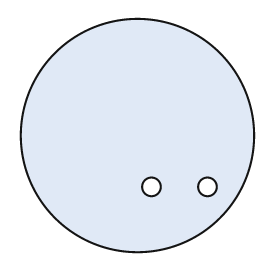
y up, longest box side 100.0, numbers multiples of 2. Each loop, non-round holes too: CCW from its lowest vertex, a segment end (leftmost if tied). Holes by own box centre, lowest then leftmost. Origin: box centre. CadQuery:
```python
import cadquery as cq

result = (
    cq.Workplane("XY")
    .moveTo(0.0, 0.0)
    .circle(50.0)
    .moveTo(6.0, -22.0)
    .circle(4.0)
    .moveTo(30.0, -22.0)
    .circle(4.0)
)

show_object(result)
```